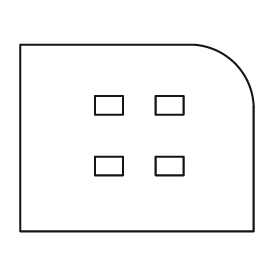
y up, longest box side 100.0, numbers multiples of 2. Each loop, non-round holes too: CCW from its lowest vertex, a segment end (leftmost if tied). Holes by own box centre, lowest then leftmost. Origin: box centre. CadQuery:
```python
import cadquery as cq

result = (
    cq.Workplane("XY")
    .moveTo(-50.0, -40.0)
    .lineTo(50.0, -40.0)
    .lineTo(50.0, 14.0)
    .threePointArc((42.0, 32.0), (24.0, 40.0))
    .lineTo(-50.0, 40.0)
    .close()
    .moveTo(-18.0, -16.0)
    .lineTo(-6.0, -16.0)
    .lineTo(-6.0, -8.0)
    .lineTo(-18.0, -8.0)
    .close()
    .moveTo(8.0, -16.0)
    .lineTo(20.0, -16.0)
    .lineTo(20.0, -8.0)
    .lineTo(8.0, -8.0)
    .close()
    .moveTo(-18.0, 10.0)
    .lineTo(-6.0, 10.0)
    .lineTo(-6.0, 18.0)
    .lineTo(-18.0, 18.0)
    .close()
    .moveTo(8.0, 10.0)
    .lineTo(20.0, 10.0)
    .lineTo(20.0, 18.0)
    .lineTo(8.0, 18.0)
    .close()
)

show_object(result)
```